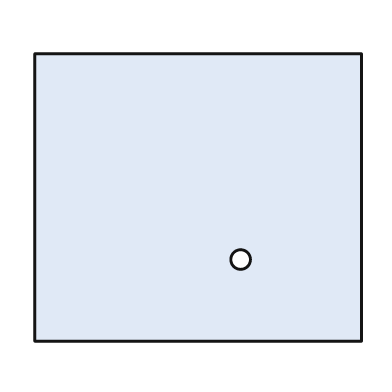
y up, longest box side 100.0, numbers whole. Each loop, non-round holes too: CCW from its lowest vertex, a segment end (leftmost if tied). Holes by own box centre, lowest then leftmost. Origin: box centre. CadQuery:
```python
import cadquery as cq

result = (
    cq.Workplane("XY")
    .moveTo(-50.0, -44.0)
    .lineTo(50.0, -44.0)
    .lineTo(50.0, 44.0)
    .lineTo(-50.0, 44.0)
    .close()
    .moveTo(13.0, -19.0)
    .circle(3.0)
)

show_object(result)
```